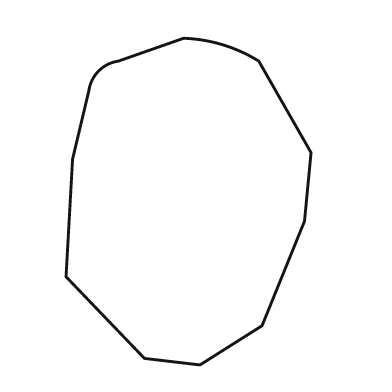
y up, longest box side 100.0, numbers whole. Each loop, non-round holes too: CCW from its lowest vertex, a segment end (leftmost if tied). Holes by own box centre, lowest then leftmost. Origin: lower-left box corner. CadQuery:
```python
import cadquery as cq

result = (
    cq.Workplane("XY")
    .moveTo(41.0, 0.0)
    .lineTo(60.0, 12.0)
    .lineTo(73.0, 44.0)
    .lineTo(75.0, 65.0)
    .lineTo(59.0, 93.0)
    .threePointArc((48.0, 98.0), (36.0, 100.0))
    .lineTo(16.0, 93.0)
    .threePointArc((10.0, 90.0), (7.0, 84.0))
    .lineTo(2.0, 63.0)
    .lineTo(0.0, 27.0)
    .lineTo(24.0, 2.0)
    .close()
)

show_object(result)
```